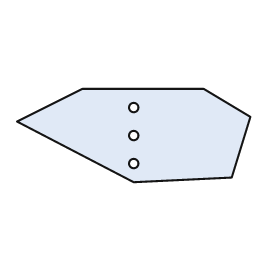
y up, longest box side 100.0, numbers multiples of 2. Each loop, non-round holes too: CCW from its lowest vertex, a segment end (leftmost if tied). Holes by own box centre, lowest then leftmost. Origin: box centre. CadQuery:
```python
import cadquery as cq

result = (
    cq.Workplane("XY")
    .moveTo(0.0, -20.0)
    .lineTo(42.0, -18.0)
    .lineTo(50.0, 8.0)
    .lineTo(30.0, 20.0)
    .lineTo(-22.0, 20.0)
    .lineTo(-50.0, 6.0)
    .close()
    .moveTo(0.0, -12.0)
    .circle(2.0)
    .moveTo(0.0, 0.0)
    .circle(2.0)
    .moveTo(0.0, 12.0)
    .circle(2.0)
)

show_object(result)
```